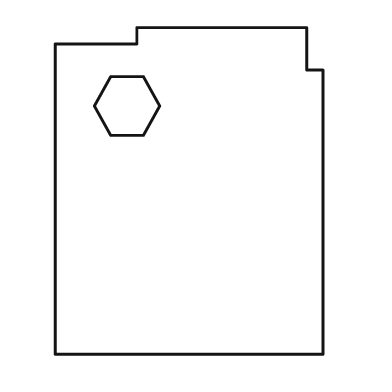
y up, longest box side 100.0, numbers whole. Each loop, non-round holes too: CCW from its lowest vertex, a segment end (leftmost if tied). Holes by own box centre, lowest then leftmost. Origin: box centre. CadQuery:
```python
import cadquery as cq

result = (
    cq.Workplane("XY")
    .moveTo(-41.0, -50.0)
    .lineTo(41.0, -50.0)
    .lineTo(41.0, 37.0)
    .lineTo(36.0, 37.0)
    .lineTo(36.0, 50.0)
    .lineTo(-16.0, 50.0)
    .lineTo(-16.0, 45.0)
    .lineTo(-41.0, 45.0)
    .close()
    .moveTo(-24.0, 17.0)
    .lineTo(-14.0, 17.0)
    .lineTo(-9.0, 26.0)
    .lineTo(-14.0, 35.0)
    .lineTo(-24.0, 35.0)
    .lineTo(-29.0, 26.0)
    .close()
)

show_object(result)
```